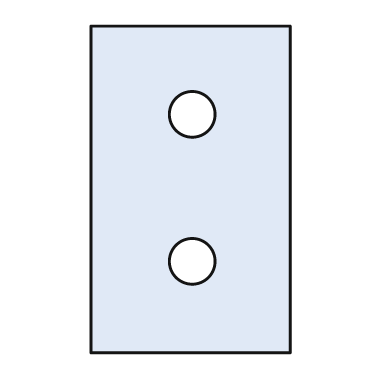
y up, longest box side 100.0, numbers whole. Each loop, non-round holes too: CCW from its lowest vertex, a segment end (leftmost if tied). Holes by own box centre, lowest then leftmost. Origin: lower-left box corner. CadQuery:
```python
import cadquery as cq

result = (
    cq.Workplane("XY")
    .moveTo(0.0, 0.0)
    .lineTo(61.0, 0.0)
    .lineTo(61.0, 100.0)
    .lineTo(0.0, 100.0)
    .close()
    .moveTo(31.0, 28.0)
    .circle(7.0)
    .moveTo(31.0, 73.0)
    .circle(7.0)
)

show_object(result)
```